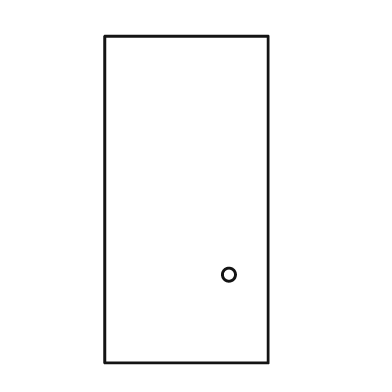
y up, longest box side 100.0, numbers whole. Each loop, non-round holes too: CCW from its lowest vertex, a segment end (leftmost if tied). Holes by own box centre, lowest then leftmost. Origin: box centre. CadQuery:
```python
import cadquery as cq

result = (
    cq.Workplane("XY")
    .moveTo(-25.0, -50.0)
    .lineTo(25.0, -50.0)
    .lineTo(25.0, 50.0)
    .lineTo(-25.0, 50.0)
    .close()
    .moveTo(13.0, -23.0)
    .circle(2.0)
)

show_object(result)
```